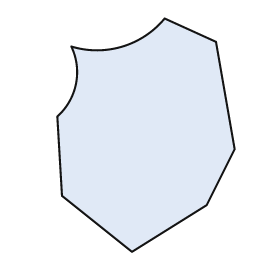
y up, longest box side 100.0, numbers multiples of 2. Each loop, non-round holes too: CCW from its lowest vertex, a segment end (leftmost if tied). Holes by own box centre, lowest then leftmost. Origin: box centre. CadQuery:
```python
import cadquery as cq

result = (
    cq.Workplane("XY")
    .moveTo(-6.0, -50.0)
    .lineTo(26.0, -30.0)
    .lineTo(38.0, -6.0)
    .lineTo(30.0, 40.0)
    .lineTo(8.0, 50.0)
    .threePointArc((-10.0, 38.0), (-32.0, 38.0))
    .threePointArc((-30.0, 22.0), (-38.0, 8.0))
    .lineTo(-36.0, -26.0)
    .close()
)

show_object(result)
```